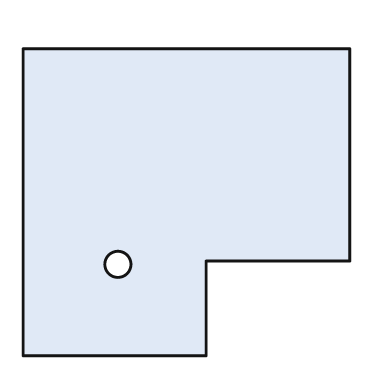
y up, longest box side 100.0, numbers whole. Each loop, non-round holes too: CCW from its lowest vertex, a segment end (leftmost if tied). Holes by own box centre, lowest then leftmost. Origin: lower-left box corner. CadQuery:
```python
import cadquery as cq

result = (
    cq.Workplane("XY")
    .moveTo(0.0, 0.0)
    .lineTo(56.0, 0.0)
    .lineTo(56.0, 29.0)
    .lineTo(100.0, 29.0)
    .lineTo(100.0, 94.0)
    .lineTo(0.0, 94.0)
    .close()
    .moveTo(29.0, 28.0)
    .circle(4.0)
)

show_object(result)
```